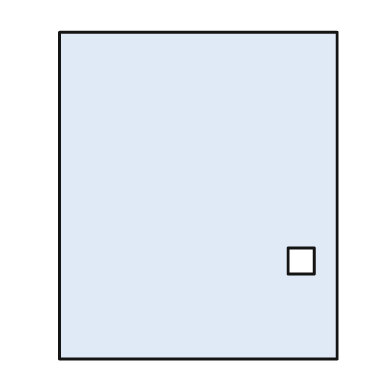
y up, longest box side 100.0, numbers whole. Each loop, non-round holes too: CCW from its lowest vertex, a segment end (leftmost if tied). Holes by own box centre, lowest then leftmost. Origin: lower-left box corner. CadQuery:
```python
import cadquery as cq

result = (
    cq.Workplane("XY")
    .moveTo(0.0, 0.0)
    .lineTo(85.0, 0.0)
    .lineTo(85.0, 100.0)
    .lineTo(0.0, 100.0)
    .close()
    .moveTo(70.0, 26.0)
    .lineTo(78.0, 26.0)
    .lineTo(78.0, 34.0)
    .lineTo(70.0, 34.0)
    .close()
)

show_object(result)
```